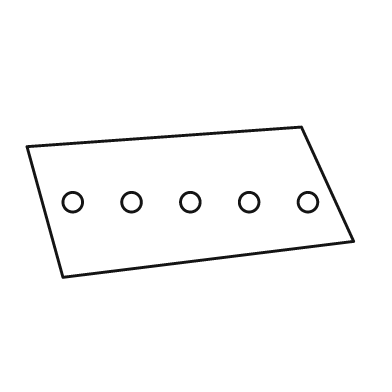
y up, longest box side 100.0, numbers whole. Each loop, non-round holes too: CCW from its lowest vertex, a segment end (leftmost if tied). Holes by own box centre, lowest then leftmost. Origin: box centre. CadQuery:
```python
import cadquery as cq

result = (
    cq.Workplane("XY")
    .moveTo(-39.0, -23.0)
    .lineTo(50.0, -12.0)
    .lineTo(34.0, 23.0)
    .lineTo(-50.0, 17.0)
    .close()
    .moveTo(-36.0, 0.0)
    .circle(3.0)
    .moveTo(-18.0, 0.0)
    .circle(3.0)
    .moveTo(0.0, 0.0)
    .circle(3.0)
    .moveTo(18.0, 0.0)
    .circle(3.0)
    .moveTo(36.0, 0.0)
    .circle(3.0)
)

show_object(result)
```